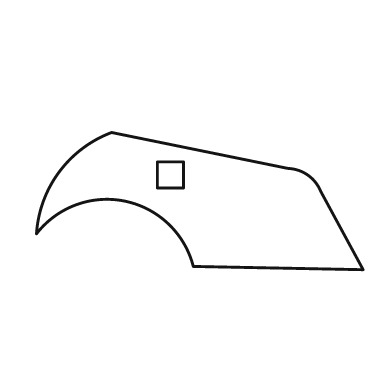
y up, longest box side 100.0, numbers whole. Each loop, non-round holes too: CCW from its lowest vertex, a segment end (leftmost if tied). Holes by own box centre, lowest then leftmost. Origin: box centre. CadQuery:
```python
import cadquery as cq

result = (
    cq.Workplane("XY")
    .moveTo(50.0, -21.0)
    .lineTo(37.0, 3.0)
    .threePointArc((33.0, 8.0), (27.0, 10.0))
    .lineTo(-27.0, 21.0)
    .threePointArc((-43.0, 9.0), (-50.0, -10.0))
    .threePointArc((-23.0, 0.0), (-2.0, -20.0))
    .close()
    .moveTo(-13.0, 4.0)
    .lineTo(-5.0, 4.0)
    .lineTo(-5.0, 12.0)
    .lineTo(-13.0, 12.0)
    .close()
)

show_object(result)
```